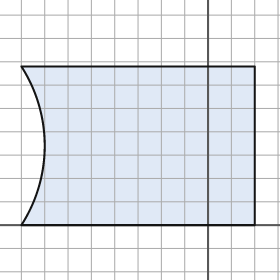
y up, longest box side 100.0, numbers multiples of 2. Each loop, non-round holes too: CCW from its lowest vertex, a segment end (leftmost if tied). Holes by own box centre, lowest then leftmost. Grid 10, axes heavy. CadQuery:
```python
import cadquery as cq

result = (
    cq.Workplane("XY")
    .moveTo(-80.0, 0.0)
    .lineTo(20.0, 0.0)
    .lineTo(20.0, 68.0)
    .lineTo(-80.0, 68.0)
    .threePointArc((-70.0, 34.0), (-80.0, 0.0))
    .close()
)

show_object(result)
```